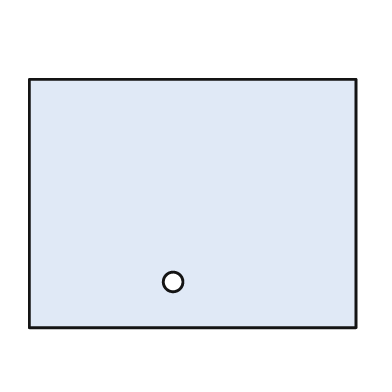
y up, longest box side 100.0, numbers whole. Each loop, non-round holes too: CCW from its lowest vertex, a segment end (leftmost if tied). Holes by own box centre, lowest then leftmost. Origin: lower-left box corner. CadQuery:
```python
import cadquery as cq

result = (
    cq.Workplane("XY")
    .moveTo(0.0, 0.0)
    .lineTo(100.0, 0.0)
    .lineTo(100.0, 76.0)
    .lineTo(0.0, 76.0)
    .close()
    .moveTo(44.0, 14.0)
    .circle(3.0)
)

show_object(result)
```